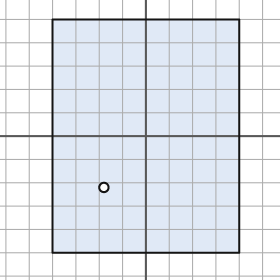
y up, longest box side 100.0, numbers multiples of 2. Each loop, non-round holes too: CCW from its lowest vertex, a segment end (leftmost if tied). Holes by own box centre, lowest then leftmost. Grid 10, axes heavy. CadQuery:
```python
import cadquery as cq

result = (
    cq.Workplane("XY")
    .moveTo(-40.0, -50.0)
    .lineTo(40.0, -50.0)
    .lineTo(40.0, 50.0)
    .lineTo(-40.0, 50.0)
    .close()
    .moveTo(-18.0, -22.0)
    .circle(2.0)
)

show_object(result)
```